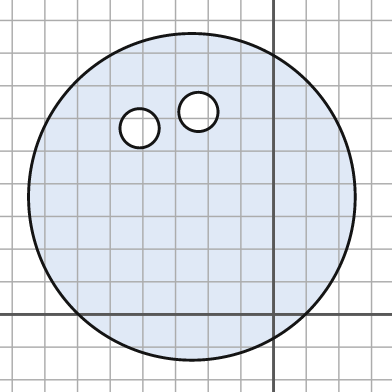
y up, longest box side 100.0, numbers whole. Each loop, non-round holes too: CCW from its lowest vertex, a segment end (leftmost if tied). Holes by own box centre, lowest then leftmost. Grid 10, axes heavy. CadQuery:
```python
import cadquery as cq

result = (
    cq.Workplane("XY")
    .moveTo(-25.0, 36.0)
    .circle(50.0)
    .moveTo(-41.0, 57.0)
    .circle(6.0)
    .moveTo(-23.0, 62.0)
    .circle(6.0)
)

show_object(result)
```